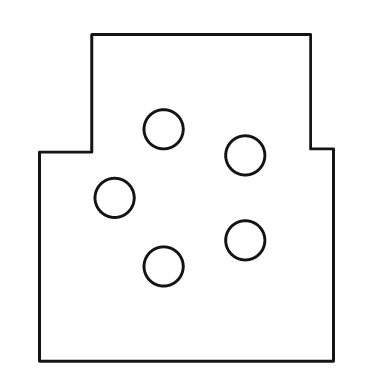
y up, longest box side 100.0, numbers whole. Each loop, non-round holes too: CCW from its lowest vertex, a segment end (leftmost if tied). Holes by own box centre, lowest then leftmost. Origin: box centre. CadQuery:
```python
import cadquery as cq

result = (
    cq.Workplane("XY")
    .moveTo(-45.0, -50.0)
    .lineTo(45.0, -50.0)
    .lineTo(45.0, 15.0)
    .lineTo(38.0, 15.0)
    .lineTo(38.0, 50.0)
    .lineTo(-29.0, 50.0)
    .lineTo(-29.0, 14.0)
    .lineTo(-45.0, 14.0)
    .close()
    .moveTo(-7.0, -21.0)
    .circle(6.0)
    .moveTo(18.0, -13.0)
    .circle(6.0)
    .moveTo(-22.0, 0.0)
    .circle(6.0)
    .moveTo(18.0, 13.0)
    .circle(6.0)
    .moveTo(-7.0, 21.0)
    .circle(6.0)
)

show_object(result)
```